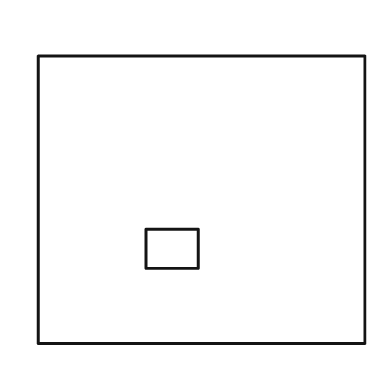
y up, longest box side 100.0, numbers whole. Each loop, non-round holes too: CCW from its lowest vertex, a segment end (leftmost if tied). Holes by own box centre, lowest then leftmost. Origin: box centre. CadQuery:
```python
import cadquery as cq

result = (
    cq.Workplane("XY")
    .moveTo(-50.0, -44.0)
    .lineTo(50.0, -44.0)
    .lineTo(50.0, 44.0)
    .lineTo(-50.0, 44.0)
    .close()
    .moveTo(-17.0, -21.0)
    .lineTo(-1.0, -21.0)
    .lineTo(-1.0, -9.0)
    .lineTo(-17.0, -9.0)
    .close()
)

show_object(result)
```